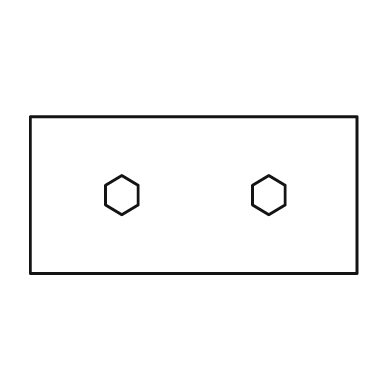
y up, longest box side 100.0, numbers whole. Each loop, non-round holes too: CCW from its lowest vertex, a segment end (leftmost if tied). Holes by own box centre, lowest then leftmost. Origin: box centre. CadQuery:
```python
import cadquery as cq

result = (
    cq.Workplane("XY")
    .moveTo(-50.0, -24.0)
    .lineTo(50.0, -24.0)
    .lineTo(50.0, 24.0)
    .lineTo(-50.0, 24.0)
    .close()
    .moveTo(-22.0, -6.0)
    .lineTo(-17.0, -3.0)
    .lineTo(-17.0, 3.0)
    .lineTo(-22.0, 6.0)
    .lineTo(-27.0, 3.0)
    .lineTo(-27.0, -3.0)
    .close()
    .moveTo(23.0, -6.0)
    .lineTo(28.0, -3.0)
    .lineTo(28.0, 3.0)
    .lineTo(23.0, 6.0)
    .lineTo(18.0, 3.0)
    .lineTo(18.0, -3.0)
    .close()
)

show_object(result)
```